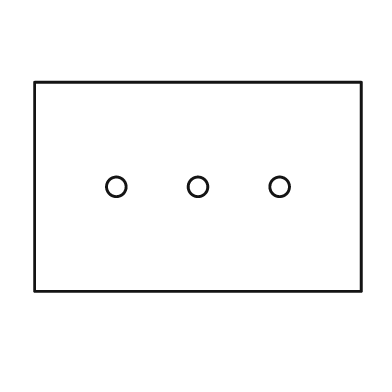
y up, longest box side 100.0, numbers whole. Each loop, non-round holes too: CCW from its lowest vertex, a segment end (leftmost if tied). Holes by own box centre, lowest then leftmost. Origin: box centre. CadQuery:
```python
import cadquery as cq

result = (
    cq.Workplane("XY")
    .moveTo(-50.0, -32.0)
    .lineTo(50.0, -32.0)
    .lineTo(50.0, 32.0)
    .lineTo(-50.0, 32.0)
    .close()
    .moveTo(-25.0, 0.0)
    .circle(3.0)
    .moveTo(0.0, 0.0)
    .circle(3.0)
    .moveTo(25.0, 0.0)
    .circle(3.0)
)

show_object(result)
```